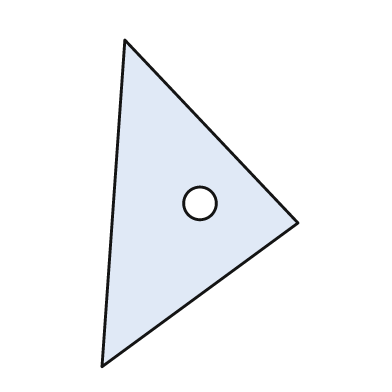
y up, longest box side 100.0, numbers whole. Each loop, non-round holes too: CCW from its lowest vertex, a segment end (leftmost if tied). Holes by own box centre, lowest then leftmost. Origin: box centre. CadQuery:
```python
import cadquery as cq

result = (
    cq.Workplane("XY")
    .moveTo(-30.0, -50.0)
    .lineTo(30.0, -6.0)
    .lineTo(-23.0, 50.0)
    .close()
    .moveTo(0.0, 0.0)
    .circle(5.0)
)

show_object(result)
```